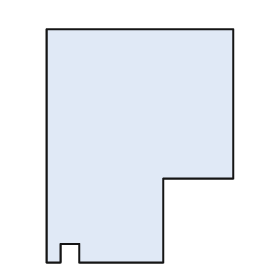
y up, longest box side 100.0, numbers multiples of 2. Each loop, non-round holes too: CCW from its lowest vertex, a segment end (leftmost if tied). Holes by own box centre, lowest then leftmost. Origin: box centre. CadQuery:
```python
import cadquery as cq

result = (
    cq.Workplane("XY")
    .moveTo(-40.0, -50.0)
    .lineTo(-34.0, -50.0)
    .lineTo(-34.0, -42.0)
    .lineTo(-26.0, -42.0)
    .lineTo(-26.0, -50.0)
    .lineTo(10.0, -50.0)
    .lineTo(10.0, -14.0)
    .lineTo(40.0, -14.0)
    .lineTo(40.0, 50.0)
    .lineTo(-40.0, 50.0)
    .close()
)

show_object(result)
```